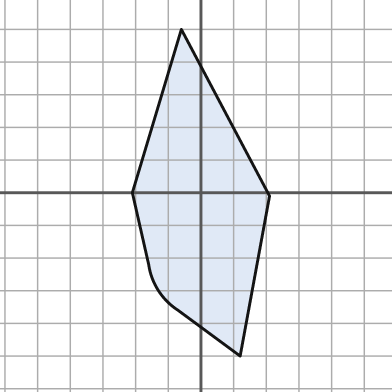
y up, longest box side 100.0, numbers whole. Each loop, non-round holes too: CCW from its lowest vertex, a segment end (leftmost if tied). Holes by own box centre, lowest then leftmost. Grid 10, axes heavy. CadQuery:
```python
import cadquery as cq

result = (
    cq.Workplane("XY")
    .moveTo(12.0, -50.0)
    .lineTo(21.0, -1.0)
    .lineTo(-6.0, 50.0)
    .lineTo(-21.0, 0.0)
    .lineTo(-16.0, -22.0)
    .threePointArc((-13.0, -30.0), (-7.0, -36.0))
    .close()
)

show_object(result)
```